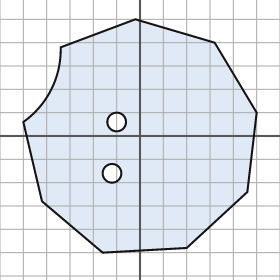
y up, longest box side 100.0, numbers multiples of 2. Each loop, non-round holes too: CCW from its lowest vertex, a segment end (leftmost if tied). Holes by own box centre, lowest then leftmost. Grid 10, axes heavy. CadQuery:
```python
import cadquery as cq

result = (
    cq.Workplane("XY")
    .moveTo(-16.0, -50.0)
    .lineTo(20.0, -48.0)
    .lineTo(46.0, -24.0)
    .lineTo(50.0, 10.0)
    .lineTo(32.0, 40.0)
    .lineTo(-2.0, 50.0)
    .lineTo(-34.0, 38.0)
    .threePointArc((-38.0, 20.0), (-50.0, 6.0))
    .lineTo(-42.0, -28.0)
    .close()
    .moveTo(-12.0, -16.0)
    .circle(4.0)
    .moveTo(-10.0, 6.0)
    .circle(4.0)
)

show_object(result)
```